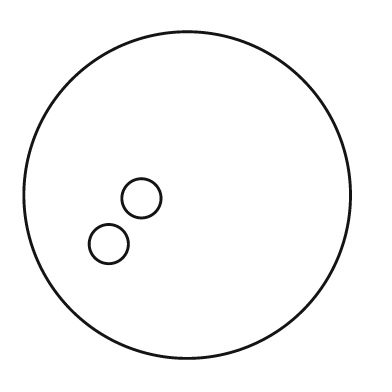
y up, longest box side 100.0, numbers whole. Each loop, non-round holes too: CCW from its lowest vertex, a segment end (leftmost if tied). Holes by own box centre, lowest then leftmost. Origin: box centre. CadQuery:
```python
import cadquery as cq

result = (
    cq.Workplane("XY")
    .moveTo(0.0, 0.0)
    .circle(50.0)
    .moveTo(-24.0, -15.0)
    .circle(6.0)
    .moveTo(-14.0, -1.0)
    .circle(6.0)
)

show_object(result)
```